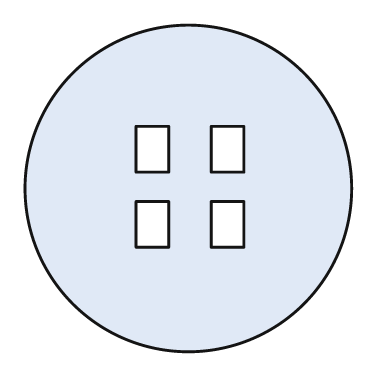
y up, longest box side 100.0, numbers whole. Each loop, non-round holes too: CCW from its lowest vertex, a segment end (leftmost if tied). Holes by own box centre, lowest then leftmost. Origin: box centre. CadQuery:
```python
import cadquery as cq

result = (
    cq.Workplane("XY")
    .moveTo(0.0, 0.0)
    .circle(50.0)
    .moveTo(-16.0, -18.0)
    .lineTo(-6.0, -18.0)
    .lineTo(-6.0, -4.0)
    .lineTo(-16.0, -4.0)
    .close()
    .moveTo(7.0, -18.0)
    .lineTo(17.0, -18.0)
    .lineTo(17.0, -4.0)
    .lineTo(7.0, -4.0)
    .close()
    .moveTo(-16.0, 5.0)
    .lineTo(-6.0, 5.0)
    .lineTo(-6.0, 19.0)
    .lineTo(-16.0, 19.0)
    .close()
    .moveTo(7.0, 5.0)
    .lineTo(17.0, 5.0)
    .lineTo(17.0, 19.0)
    .lineTo(7.0, 19.0)
    .close()
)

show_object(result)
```